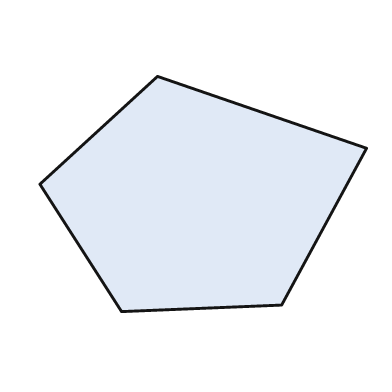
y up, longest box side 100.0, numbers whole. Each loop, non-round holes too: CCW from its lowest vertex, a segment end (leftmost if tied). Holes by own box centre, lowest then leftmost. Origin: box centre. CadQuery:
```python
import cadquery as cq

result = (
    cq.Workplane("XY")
    .moveTo(-25.0, -36.0)
    .lineTo(24.0, -34.0)
    .lineTo(50.0, 14.0)
    .lineTo(-14.0, 36.0)
    .lineTo(-50.0, 3.0)
    .close()
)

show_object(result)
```